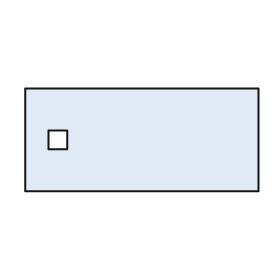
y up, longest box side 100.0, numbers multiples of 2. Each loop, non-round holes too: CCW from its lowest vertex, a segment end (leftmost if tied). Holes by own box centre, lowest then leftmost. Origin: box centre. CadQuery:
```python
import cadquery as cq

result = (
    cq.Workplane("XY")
    .moveTo(-50.0, -22.0)
    .lineTo(50.0, -22.0)
    .lineTo(50.0, 22.0)
    .lineTo(-50.0, 22.0)
    .close()
    .moveTo(-40.0, -4.0)
    .lineTo(-32.0, -4.0)
    .lineTo(-32.0, 4.0)
    .lineTo(-40.0, 4.0)
    .close()
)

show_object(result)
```